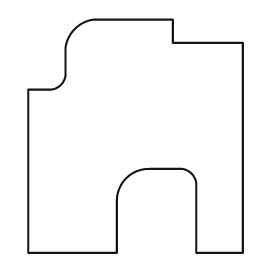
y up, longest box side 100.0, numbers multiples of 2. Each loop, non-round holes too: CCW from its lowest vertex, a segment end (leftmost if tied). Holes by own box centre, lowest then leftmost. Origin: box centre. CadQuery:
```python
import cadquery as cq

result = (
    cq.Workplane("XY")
    .moveTo(-46.0, -50.0)
    .lineTo(-8.0, -50.0)
    .lineTo(-8.0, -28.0)
    .threePointArc((-4.0, -18.0), (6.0, -14.0))
    .lineTo(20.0, -14.0)
    .threePointArc((24.0, -16.0), (26.0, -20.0))
    .lineTo(26.0, -50.0)
    .lineTo(46.0, -50.0)
    .lineTo(46.0, 40.0)
    .lineTo(16.0, 40.0)
    .lineTo(16.0, 50.0)
    .lineTo(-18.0, 50.0)
    .threePointArc((-26.0, 46.0), (-30.0, 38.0))
    .lineTo(-30.0, 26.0)
    .threePointArc((-32.0, 22.0), (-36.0, 20.0))
    .lineTo(-46.0, 20.0)
    .close()
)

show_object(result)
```